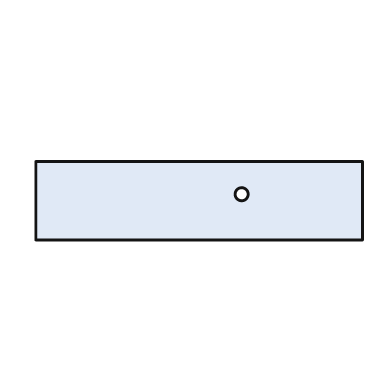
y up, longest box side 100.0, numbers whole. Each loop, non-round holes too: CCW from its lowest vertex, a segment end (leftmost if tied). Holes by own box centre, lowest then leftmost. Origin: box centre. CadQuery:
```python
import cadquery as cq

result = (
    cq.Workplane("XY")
    .moveTo(-50.0, -12.0)
    .lineTo(50.0, -12.0)
    .lineTo(50.0, 12.0)
    .lineTo(-50.0, 12.0)
    .close()
    .moveTo(13.0, 2.0)
    .circle(2.0)
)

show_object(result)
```